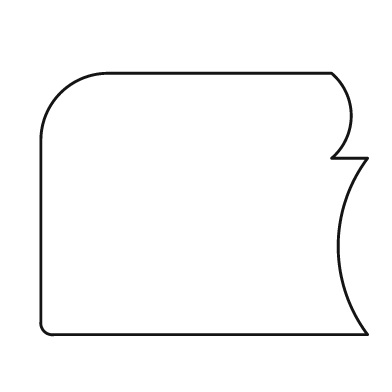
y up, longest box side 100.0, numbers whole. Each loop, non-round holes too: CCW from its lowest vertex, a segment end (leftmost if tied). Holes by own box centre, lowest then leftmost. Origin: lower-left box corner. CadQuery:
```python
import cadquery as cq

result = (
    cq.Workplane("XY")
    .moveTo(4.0, 0.0)
    .lineTo(100.0, 0.0)
    .threePointArc((91.0, 27.0), (100.0, 54.0))
    .lineTo(89.0, 54.0)
    .threePointArc((95.0, 67.0), (89.0, 80.0))
    .lineTo(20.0, 80.0)
    .threePointArc((6.0, 74.0), (0.0, 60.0))
    .lineTo(0.0, 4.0)
    .threePointArc((1.0, 1.0), (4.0, 0.0))
    .close()
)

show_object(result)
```